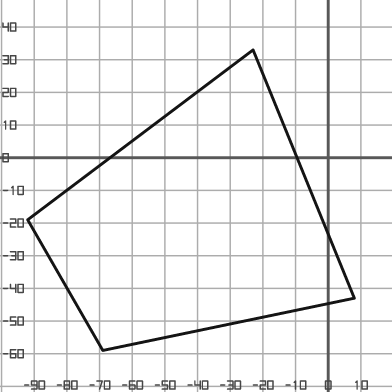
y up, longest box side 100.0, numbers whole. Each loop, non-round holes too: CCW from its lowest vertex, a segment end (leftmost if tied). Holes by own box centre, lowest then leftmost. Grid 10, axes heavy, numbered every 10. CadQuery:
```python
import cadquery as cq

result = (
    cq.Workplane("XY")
    .moveTo(-69.0, -59.0)
    .lineTo(8.0, -43.0)
    .lineTo(-23.0, 33.0)
    .lineTo(-92.0, -19.0)
    .close()
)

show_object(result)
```